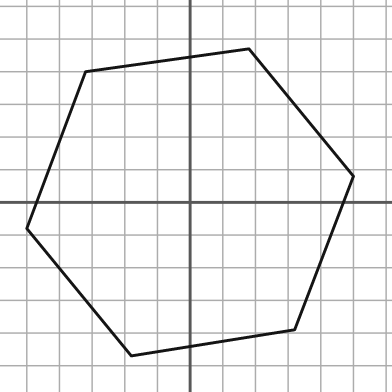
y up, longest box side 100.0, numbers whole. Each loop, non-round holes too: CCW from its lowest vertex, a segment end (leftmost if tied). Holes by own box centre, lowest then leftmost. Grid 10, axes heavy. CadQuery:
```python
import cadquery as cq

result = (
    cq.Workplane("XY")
    .moveTo(-18.0, -47.0)
    .lineTo(32.0, -39.0)
    .lineTo(50.0, 8.0)
    .lineTo(18.0, 47.0)
    .lineTo(-32.0, 40.0)
    .lineTo(-50.0, -8.0)
    .close()
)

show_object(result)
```